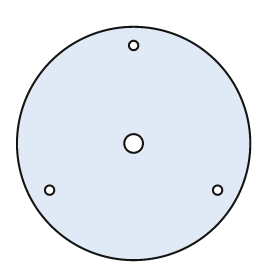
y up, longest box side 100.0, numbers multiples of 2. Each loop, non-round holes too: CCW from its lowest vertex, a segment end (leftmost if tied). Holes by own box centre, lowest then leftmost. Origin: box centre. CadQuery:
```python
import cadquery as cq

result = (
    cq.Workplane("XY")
    .moveTo(0.0, 0.0)
    .circle(50.0)
    .moveTo(-36.0, -20.0)
    .circle(2.0)
    .moveTo(36.0, -20.0)
    .circle(2.0)
    .moveTo(0.0, 0.0)
    .circle(4.0)
    .moveTo(0.0, 42.0)
    .circle(2.0)
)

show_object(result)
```